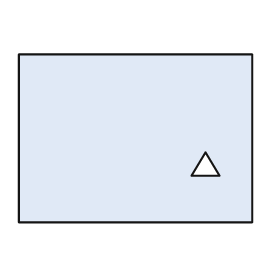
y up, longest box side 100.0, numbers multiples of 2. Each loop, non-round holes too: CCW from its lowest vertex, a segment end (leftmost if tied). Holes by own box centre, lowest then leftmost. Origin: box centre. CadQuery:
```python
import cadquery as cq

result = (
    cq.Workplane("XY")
    .moveTo(-50.0, -36.0)
    .lineTo(50.0, -36.0)
    .lineTo(50.0, 36.0)
    .lineTo(-50.0, 36.0)
    .close()
    .moveTo(24.0, -16.0)
    .lineTo(36.0, -16.0)
    .lineTo(30.0, -6.0)
    .close()
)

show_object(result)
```